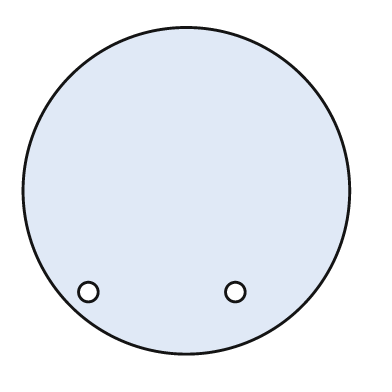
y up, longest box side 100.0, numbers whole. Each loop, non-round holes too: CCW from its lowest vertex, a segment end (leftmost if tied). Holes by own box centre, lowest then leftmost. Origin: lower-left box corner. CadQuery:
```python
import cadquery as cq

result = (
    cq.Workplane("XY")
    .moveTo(50.0, 50.0)
    .circle(50.0)
    .moveTo(20.0, 19.0)
    .circle(3.0)
    .moveTo(65.0, 19.0)
    .circle(3.0)
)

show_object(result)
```